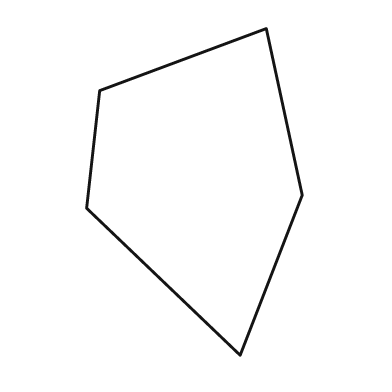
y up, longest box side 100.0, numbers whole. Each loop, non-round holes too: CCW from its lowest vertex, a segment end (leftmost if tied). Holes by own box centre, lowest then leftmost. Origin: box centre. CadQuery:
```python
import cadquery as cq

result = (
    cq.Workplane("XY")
    .moveTo(14.0, -50.0)
    .lineTo(33.0, -1.0)
    .lineTo(22.0, 50.0)
    .lineTo(-29.0, 31.0)
    .lineTo(-33.0, -5.0)
    .close()
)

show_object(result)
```